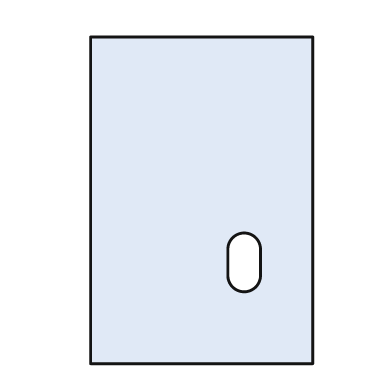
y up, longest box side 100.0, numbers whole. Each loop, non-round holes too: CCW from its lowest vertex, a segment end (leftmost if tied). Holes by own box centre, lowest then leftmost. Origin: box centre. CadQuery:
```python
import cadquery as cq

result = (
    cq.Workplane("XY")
    .moveTo(-34.0, -50.0)
    .lineTo(34.0, -50.0)
    .lineTo(34.0, 50.0)
    .lineTo(-34.0, 50.0)
    .close()
    .moveTo(8.0, -23.0)
    .threePointArc((13.0, -28.0), (18.0, -23.0))
    .lineTo(18.0, -15.0)
    .threePointArc((13.0, -10.0), (8.0, -15.0))
    .close()
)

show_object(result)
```